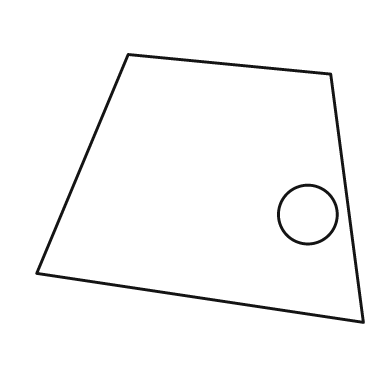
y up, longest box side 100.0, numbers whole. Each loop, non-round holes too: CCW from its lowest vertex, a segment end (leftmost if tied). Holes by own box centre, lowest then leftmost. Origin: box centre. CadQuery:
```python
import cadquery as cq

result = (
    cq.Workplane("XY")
    .moveTo(50.0, -41.0)
    .lineTo(40.0, 35.0)
    .lineTo(-22.0, 41.0)
    .lineTo(-50.0, -26.0)
    .close()
    .moveTo(33.0, -8.0)
    .circle(9.0)
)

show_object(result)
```